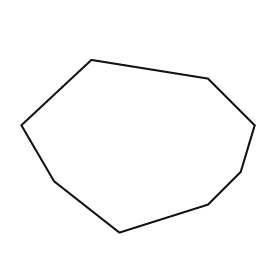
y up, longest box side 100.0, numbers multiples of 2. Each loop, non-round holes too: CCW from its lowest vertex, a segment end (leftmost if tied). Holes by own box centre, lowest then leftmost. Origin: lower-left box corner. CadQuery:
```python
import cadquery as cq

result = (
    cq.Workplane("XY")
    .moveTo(42.0, 0.0)
    .lineTo(80.0, 12.0)
    .lineTo(94.0, 26.0)
    .lineTo(100.0, 46.0)
    .lineTo(80.0, 66.0)
    .lineTo(30.0, 74.0)
    .lineTo(0.0, 46.0)
    .lineTo(14.0, 22.0)
    .close()
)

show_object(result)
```